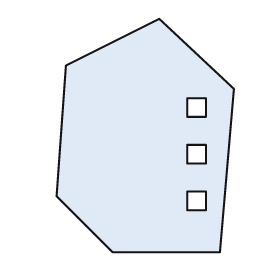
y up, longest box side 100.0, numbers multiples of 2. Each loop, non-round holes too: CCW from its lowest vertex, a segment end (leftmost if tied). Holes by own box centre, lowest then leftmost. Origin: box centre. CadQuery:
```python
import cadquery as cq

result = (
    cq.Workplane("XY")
    .moveTo(-14.0, -50.0)
    .lineTo(32.0, -50.0)
    .lineTo(38.0, 20.0)
    .lineTo(6.0, 50.0)
    .lineTo(-34.0, 30.0)
    .lineTo(-38.0, -26.0)
    .close()
    .moveTo(18.0, -32.0)
    .lineTo(26.0, -32.0)
    .lineTo(26.0, -24.0)
    .lineTo(18.0, -24.0)
    .close()
    .moveTo(18.0, -12.0)
    .lineTo(26.0, -12.0)
    .lineTo(26.0, -4.0)
    .lineTo(18.0, -4.0)
    .close()
    .moveTo(18.0, 8.0)
    .lineTo(26.0, 8.0)
    .lineTo(26.0, 16.0)
    .lineTo(18.0, 16.0)
    .close()
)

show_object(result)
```